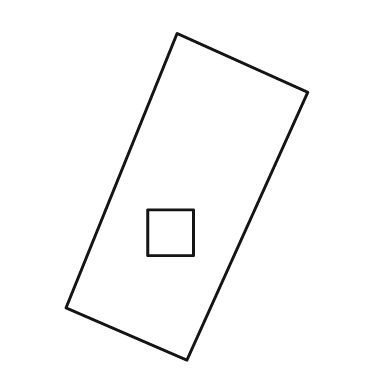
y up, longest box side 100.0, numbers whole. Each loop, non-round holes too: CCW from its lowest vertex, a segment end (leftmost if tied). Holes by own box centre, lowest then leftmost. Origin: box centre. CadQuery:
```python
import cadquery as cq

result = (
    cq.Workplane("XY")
    .moveTo(0.0, -50.0)
    .lineTo(37.0, 32.0)
    .lineTo(-3.0, 50.0)
    .lineTo(-37.0, -34.0)
    .close()
    .moveTo(-12.0, -18.0)
    .lineTo(2.0, -18.0)
    .lineTo(2.0, -4.0)
    .lineTo(-12.0, -4.0)
    .close()
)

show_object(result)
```